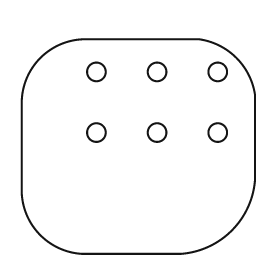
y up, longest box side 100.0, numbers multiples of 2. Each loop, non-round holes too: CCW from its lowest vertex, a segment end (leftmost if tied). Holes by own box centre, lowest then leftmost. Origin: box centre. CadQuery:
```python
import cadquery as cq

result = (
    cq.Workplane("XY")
    .moveTo(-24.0, -46.0)
    .lineTo(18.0, -46.0)
    .threePointArc((40.0, -36.0), (50.0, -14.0))
    .lineTo(50.0, 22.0)
    .threePointArc((42.0, 38.0), (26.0, 46.0))
    .lineTo(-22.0, 46.0)
    .threePointArc((-42.0, 38.0), (-50.0, 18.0))
    .lineTo(-50.0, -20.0)
    .threePointArc((-42.0, -38.0), (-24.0, -46.0))
    .close()
    .moveTo(-18.0, 6.0)
    .circle(4.0)
    .moveTo(8.0, 6.0)
    .circle(4.0)
    .moveTo(34.0, 6.0)
    .circle(4.0)
    .moveTo(-18.0, 32.0)
    .circle(4.0)
    .moveTo(8.0, 32.0)
    .circle(4.0)
    .moveTo(34.0, 32.0)
    .circle(4.0)
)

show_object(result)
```